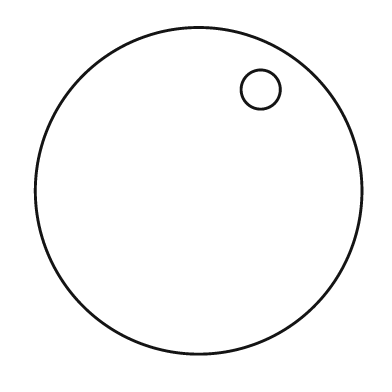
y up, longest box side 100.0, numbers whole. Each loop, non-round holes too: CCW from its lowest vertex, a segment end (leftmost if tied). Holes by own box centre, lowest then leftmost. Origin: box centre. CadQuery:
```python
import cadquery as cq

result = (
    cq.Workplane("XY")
    .moveTo(0.0, 0.0)
    .circle(50.0)
    .moveTo(19.0, 31.0)
    .circle(6.0)
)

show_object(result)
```